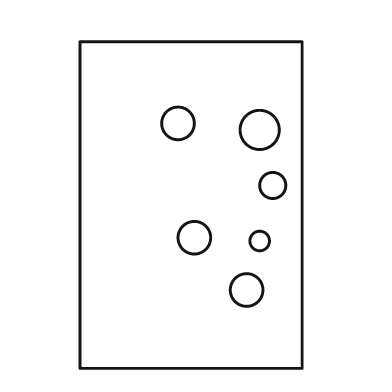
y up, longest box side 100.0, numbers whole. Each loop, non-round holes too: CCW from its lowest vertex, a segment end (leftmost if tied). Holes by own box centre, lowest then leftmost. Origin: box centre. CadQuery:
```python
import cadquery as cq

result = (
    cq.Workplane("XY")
    .moveTo(-34.0, -50.0)
    .lineTo(34.0, -50.0)
    .lineTo(34.0, 50.0)
    .lineTo(-34.0, 50.0)
    .close()
    .moveTo(17.0, -26.0)
    .circle(5.0)
    .moveTo(21.0, -11.0)
    .circle(3.0)
    .moveTo(1.0, -10.0)
    .circle(5.0)
    .moveTo(25.0, 6.0)
    .circle(4.0)
    .moveTo(21.0, 23.0)
    .circle(6.0)
    .moveTo(-4.0, 25.0)
    .circle(5.0)
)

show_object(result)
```